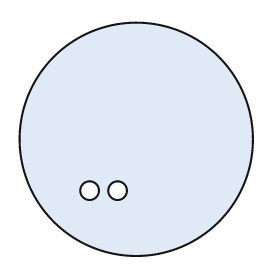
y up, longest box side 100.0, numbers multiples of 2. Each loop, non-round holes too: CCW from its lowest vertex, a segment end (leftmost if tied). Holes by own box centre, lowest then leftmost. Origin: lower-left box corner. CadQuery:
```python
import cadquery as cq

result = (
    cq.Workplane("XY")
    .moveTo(50.0, 50.0)
    .circle(50.0)
    .moveTo(30.0, 28.0)
    .circle(4.0)
    .moveTo(42.0, 28.0)
    .circle(4.0)
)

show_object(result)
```